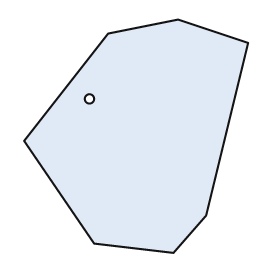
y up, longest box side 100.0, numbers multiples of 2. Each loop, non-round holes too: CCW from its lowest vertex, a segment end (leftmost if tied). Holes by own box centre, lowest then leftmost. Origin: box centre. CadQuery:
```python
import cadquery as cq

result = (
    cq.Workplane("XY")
    .moveTo(16.0, -50.0)
    .lineTo(30.0, -34.0)
    .lineTo(48.0, 40.0)
    .lineTo(18.0, 50.0)
    .lineTo(-12.0, 44.0)
    .lineTo(-48.0, -2.0)
    .lineTo(-18.0, -46.0)
    .close()
    .moveTo(-20.0, 16.0)
    .circle(2.0)
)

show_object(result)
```